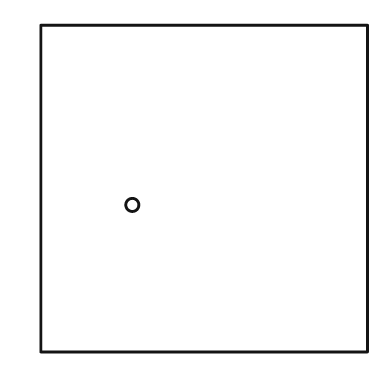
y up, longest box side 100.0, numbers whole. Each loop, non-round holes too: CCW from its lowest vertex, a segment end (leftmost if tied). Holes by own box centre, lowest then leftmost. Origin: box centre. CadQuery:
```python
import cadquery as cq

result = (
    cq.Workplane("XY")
    .moveTo(-50.0, -50.0)
    .lineTo(50.0, -50.0)
    .lineTo(50.0, 50.0)
    .lineTo(-50.0, 50.0)
    .close()
    .moveTo(-22.0, -5.0)
    .circle(2.0)
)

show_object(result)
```